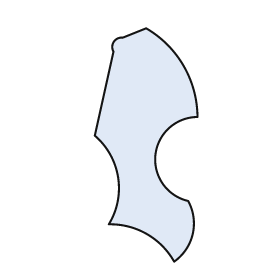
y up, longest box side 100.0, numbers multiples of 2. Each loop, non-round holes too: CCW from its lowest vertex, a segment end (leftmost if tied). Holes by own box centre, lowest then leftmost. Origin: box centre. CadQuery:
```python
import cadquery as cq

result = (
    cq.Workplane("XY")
    .moveTo(12.0, -50.0)
    .threePointArc((20.0, -38.0), (18.0, -24.0))
    .threePointArc((4.0, -4.0), (22.0, 12.0))
    .threePointArc((16.0, 34.0), (0.0, 50.0))
    .lineTo(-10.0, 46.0)
    .threePointArc((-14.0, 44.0), (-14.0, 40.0))
    .lineTo(-22.0, 4.0)
    .threePointArc((-12.0, -14.0), (-16.0, -34.0))
    .threePointArc((0.0, -38.0), (12.0, -50.0))
    .close()
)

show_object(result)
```